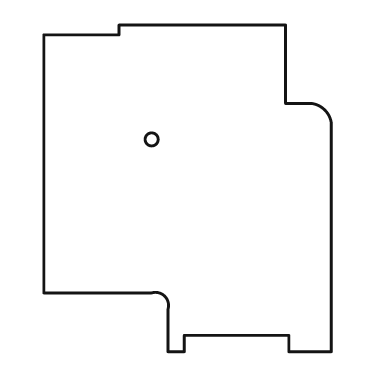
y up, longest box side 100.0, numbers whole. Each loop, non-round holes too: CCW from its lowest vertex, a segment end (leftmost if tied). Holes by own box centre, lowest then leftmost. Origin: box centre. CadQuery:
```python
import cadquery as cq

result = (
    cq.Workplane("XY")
    .moveTo(-6.0, -50.0)
    .lineTo(-1.0, -50.0)
    .lineTo(-1.0, -45.0)
    .lineTo(31.0, -45.0)
    .lineTo(31.0, -50.0)
    .lineTo(44.0, -50.0)
    .lineTo(44.0, 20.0)
    .threePointArc((42.0, 24.0), (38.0, 26.0))
    .lineTo(30.0, 26.0)
    .lineTo(30.0, 50.0)
    .lineTo(-21.0, 50.0)
    .lineTo(-21.0, 47.0)
    .lineTo(-44.0, 47.0)
    .lineTo(-44.0, -32.0)
    .lineTo(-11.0, -32.0)
    .threePointArc((-7.0, -33.0), (-6.0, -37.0))
    .close()
    .moveTo(-11.0, 15.0)
    .circle(2.0)
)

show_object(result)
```